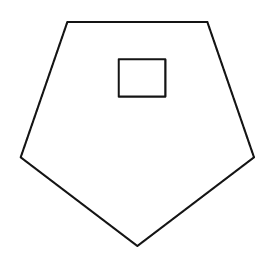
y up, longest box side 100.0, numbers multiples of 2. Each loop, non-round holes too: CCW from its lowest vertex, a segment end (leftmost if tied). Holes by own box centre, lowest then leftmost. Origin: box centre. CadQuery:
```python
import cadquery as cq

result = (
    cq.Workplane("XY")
    .moveTo(0.0, -48.0)
    .lineTo(50.0, -10.0)
    .lineTo(30.0, 48.0)
    .lineTo(-30.0, 48.0)
    .lineTo(-50.0, -10.0)
    .close()
    .moveTo(-8.0, 16.0)
    .lineTo(12.0, 16.0)
    .lineTo(12.0, 32.0)
    .lineTo(-8.0, 32.0)
    .close()
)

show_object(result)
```